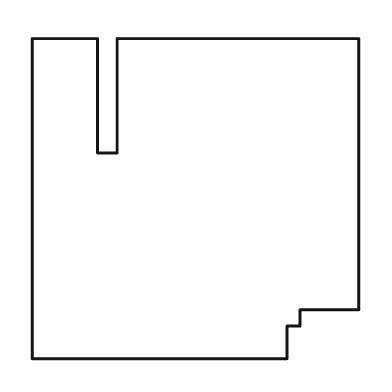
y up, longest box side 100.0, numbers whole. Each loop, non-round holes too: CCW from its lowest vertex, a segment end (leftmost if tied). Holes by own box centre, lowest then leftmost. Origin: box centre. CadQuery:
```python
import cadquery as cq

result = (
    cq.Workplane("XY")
    .moveTo(-50.0, -49.0)
    .lineTo(28.0, -49.0)
    .lineTo(28.0, -39.0)
    .lineTo(32.0, -39.0)
    .lineTo(32.0, -34.0)
    .lineTo(50.0, -34.0)
    .lineTo(50.0, 49.0)
    .lineTo(-24.0, 49.0)
    .lineTo(-24.0, 14.0)
    .lineTo(-30.0, 14.0)
    .lineTo(-30.0, 49.0)
    .lineTo(-50.0, 49.0)
    .close()
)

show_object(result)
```